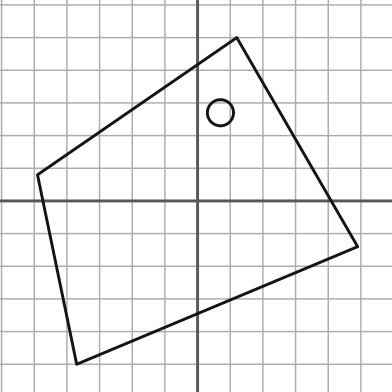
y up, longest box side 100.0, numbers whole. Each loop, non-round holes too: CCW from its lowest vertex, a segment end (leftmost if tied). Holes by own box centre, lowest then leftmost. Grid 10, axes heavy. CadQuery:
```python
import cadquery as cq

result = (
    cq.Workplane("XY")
    .moveTo(-37.0, -50.0)
    .lineTo(49.0, -14.0)
    .lineTo(12.0, 50.0)
    .lineTo(-49.0, 8.0)
    .close()
    .moveTo(7.0, 27.0)
    .circle(4.0)
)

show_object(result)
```